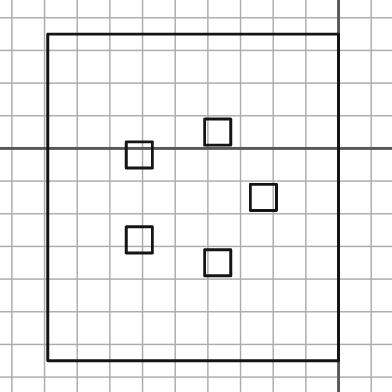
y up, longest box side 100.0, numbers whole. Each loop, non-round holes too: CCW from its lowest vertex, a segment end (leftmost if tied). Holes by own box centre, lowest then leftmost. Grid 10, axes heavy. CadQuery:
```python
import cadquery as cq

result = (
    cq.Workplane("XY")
    .moveTo(-89.0, -65.0)
    .lineTo(0.0, -65.0)
    .lineTo(0.0, 35.0)
    .lineTo(-89.0, 35.0)
    .close()
    .moveTo(-41.0, -39.0)
    .lineTo(-33.0, -39.0)
    .lineTo(-33.0, -31.0)
    .lineTo(-41.0, -31.0)
    .close()
    .moveTo(-65.0, -32.0)
    .lineTo(-57.0, -32.0)
    .lineTo(-57.0, -24.0)
    .lineTo(-65.0, -24.0)
    .close()
    .moveTo(-27.0, -19.0)
    .lineTo(-19.0, -19.0)
    .lineTo(-19.0, -11.0)
    .lineTo(-27.0, -11.0)
    .close()
    .moveTo(-65.0, -6.0)
    .lineTo(-57.0, -6.0)
    .lineTo(-57.0, 2.0)
    .lineTo(-65.0, 2.0)
    .close()
    .moveTo(-41.0, 1.0)
    .lineTo(-33.0, 1.0)
    .lineTo(-33.0, 9.0)
    .lineTo(-41.0, 9.0)
    .close()
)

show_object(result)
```